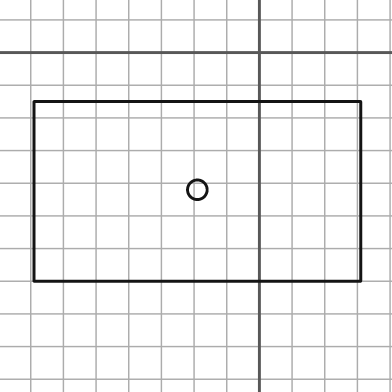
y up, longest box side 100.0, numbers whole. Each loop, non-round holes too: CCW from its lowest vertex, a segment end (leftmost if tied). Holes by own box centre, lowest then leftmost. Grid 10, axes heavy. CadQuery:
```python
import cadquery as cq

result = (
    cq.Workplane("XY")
    .moveTo(-69.0, -70.0)
    .lineTo(31.0, -70.0)
    .lineTo(31.0, -15.0)
    .lineTo(-69.0, -15.0)
    .close()
    .moveTo(-19.0, -42.0)
    .circle(3.0)
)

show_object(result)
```